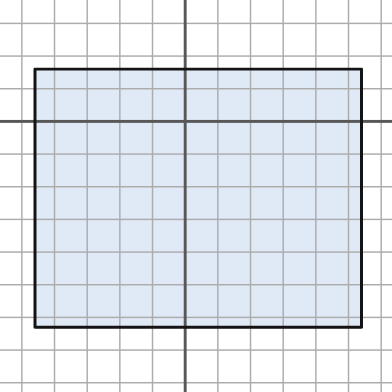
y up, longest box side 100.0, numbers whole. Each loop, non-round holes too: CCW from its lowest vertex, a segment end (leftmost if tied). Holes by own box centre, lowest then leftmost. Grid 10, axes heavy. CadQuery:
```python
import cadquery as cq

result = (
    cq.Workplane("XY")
    .moveTo(-46.0, -63.0)
    .lineTo(54.0, -63.0)
    .lineTo(54.0, 16.0)
    .lineTo(-46.0, 16.0)
    .close()
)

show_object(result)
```